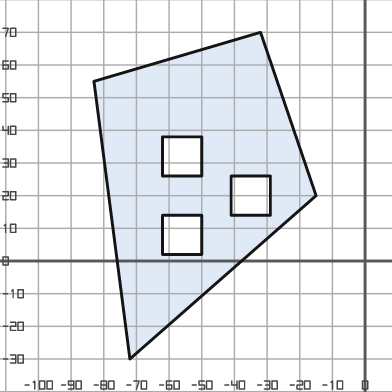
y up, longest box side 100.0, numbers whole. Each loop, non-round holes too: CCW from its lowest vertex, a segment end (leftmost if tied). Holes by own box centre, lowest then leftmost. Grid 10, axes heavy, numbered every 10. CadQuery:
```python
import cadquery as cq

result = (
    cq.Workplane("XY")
    .moveTo(-72.0, -30.0)
    .lineTo(-15.0, 20.0)
    .lineTo(-32.0, 70.0)
    .lineTo(-83.0, 55.0)
    .close()
    .moveTo(-62.0, 2.0)
    .lineTo(-50.0, 2.0)
    .lineTo(-50.0, 14.0)
    .lineTo(-62.0, 14.0)
    .close()
    .moveTo(-41.0, 14.0)
    .lineTo(-29.0, 14.0)
    .lineTo(-29.0, 26.0)
    .lineTo(-41.0, 26.0)
    .close()
    .moveTo(-62.0, 26.0)
    .lineTo(-50.0, 26.0)
    .lineTo(-50.0, 38.0)
    .lineTo(-62.0, 38.0)
    .close()
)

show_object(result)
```